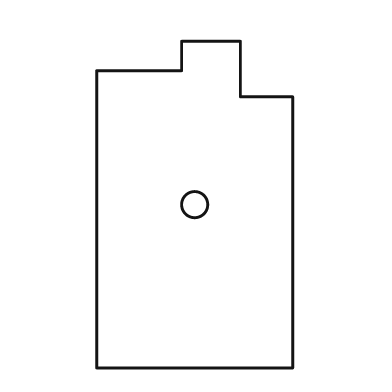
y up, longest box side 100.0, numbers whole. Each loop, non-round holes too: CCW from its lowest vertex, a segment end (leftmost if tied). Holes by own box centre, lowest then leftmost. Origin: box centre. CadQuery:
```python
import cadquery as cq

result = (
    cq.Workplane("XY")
    .moveTo(-30.0, -50.0)
    .lineTo(30.0, -50.0)
    .lineTo(30.0, 33.0)
    .lineTo(14.0, 33.0)
    .lineTo(14.0, 50.0)
    .lineTo(-4.0, 50.0)
    .lineTo(-4.0, 41.0)
    .lineTo(-30.0, 41.0)
    .close()
    .moveTo(0.0, 0.0)
    .circle(4.0)
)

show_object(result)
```